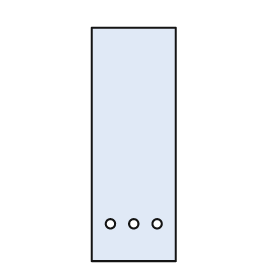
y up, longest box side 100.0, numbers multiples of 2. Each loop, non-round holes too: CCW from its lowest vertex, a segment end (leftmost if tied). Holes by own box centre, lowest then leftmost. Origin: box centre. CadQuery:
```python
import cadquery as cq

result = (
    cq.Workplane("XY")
    .moveTo(-18.0, -50.0)
    .lineTo(18.0, -50.0)
    .lineTo(18.0, 50.0)
    .lineTo(-18.0, 50.0)
    .close()
    .moveTo(-10.0, -34.0)
    .circle(2.0)
    .moveTo(0.0, -34.0)
    .circle(2.0)
    .moveTo(10.0, -34.0)
    .circle(2.0)
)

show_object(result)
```